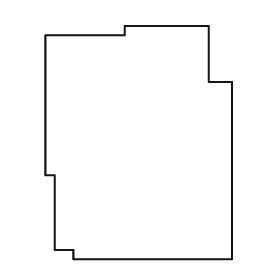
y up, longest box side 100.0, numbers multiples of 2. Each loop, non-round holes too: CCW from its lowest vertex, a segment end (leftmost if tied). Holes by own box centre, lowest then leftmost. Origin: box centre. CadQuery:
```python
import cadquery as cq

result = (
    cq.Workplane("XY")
    .moveTo(-28.0, -50.0)
    .lineTo(40.0, -50.0)
    .lineTo(40.0, 26.0)
    .lineTo(30.0, 26.0)
    .lineTo(30.0, 50.0)
    .lineTo(-6.0, 50.0)
    .lineTo(-6.0, 46.0)
    .lineTo(-40.0, 46.0)
    .lineTo(-40.0, -14.0)
    .lineTo(-36.0, -14.0)
    .lineTo(-36.0, -46.0)
    .lineTo(-28.0, -46.0)
    .close()
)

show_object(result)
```